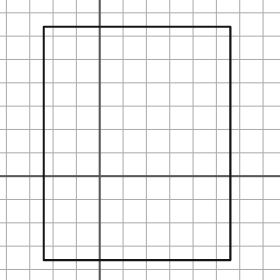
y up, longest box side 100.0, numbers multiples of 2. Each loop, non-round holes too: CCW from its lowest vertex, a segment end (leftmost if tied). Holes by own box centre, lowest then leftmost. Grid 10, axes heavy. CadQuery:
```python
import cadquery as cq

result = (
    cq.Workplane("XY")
    .moveTo(-24.0, -36.0)
    .lineTo(56.0, -36.0)
    .lineTo(56.0, 64.0)
    .lineTo(-24.0, 64.0)
    .close()
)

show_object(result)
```